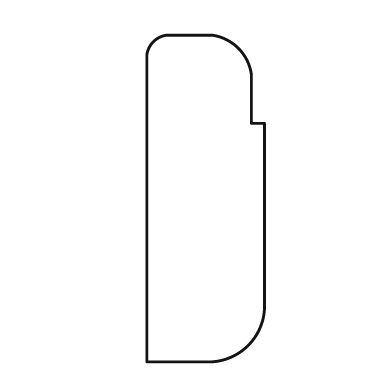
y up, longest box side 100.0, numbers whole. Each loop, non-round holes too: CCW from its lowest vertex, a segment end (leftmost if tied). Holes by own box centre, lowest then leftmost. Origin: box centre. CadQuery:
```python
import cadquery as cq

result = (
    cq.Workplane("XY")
    .moveTo(-18.0, -50.0)
    .lineTo(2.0, -50.0)
    .threePointArc((13.0, -45.0), (18.0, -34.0))
    .lineTo(18.0, 23.0)
    .lineTo(14.0, 23.0)
    .lineTo(14.0, 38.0)
    .threePointArc((10.0, 46.0), (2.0, 50.0))
    .lineTo(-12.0, 50.0)
    .threePointArc((-16.0, 48.0), (-18.0, 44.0))
    .close()
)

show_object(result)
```